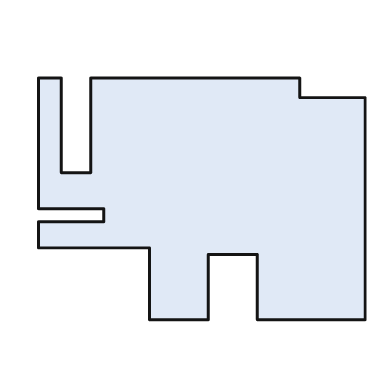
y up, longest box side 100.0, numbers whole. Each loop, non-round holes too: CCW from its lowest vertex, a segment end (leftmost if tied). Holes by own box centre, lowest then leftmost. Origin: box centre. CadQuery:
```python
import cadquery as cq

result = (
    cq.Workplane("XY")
    .moveTo(-16.0, -37.0)
    .lineTo(2.0, -37.0)
    .lineTo(2.0, -17.0)
    .lineTo(17.0, -17.0)
    .lineTo(17.0, -37.0)
    .lineTo(50.0, -37.0)
    .lineTo(50.0, 31.0)
    .lineTo(30.0, 31.0)
    .lineTo(30.0, 37.0)
    .lineTo(-34.0, 37.0)
    .lineTo(-34.0, 8.0)
    .lineTo(-43.0, 8.0)
    .lineTo(-43.0, 37.0)
    .lineTo(-50.0, 37.0)
    .lineTo(-50.0, -3.0)
    .lineTo(-30.0, -3.0)
    .lineTo(-30.0, -7.0)
    .lineTo(-50.0, -7.0)
    .lineTo(-50.0, -15.0)
    .lineTo(-16.0, -15.0)
    .close()
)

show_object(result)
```